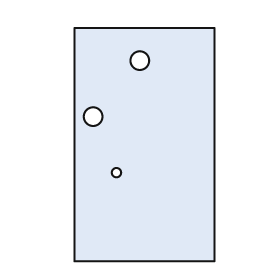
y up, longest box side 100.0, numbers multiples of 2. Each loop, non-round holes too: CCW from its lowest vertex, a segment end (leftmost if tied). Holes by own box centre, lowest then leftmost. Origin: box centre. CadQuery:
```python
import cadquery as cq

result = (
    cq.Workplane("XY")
    .moveTo(-30.0, -50.0)
    .lineTo(30.0, -50.0)
    .lineTo(30.0, 50.0)
    .lineTo(-30.0, 50.0)
    .close()
    .moveTo(-12.0, -12.0)
    .circle(2.0)
    .moveTo(-22.0, 12.0)
    .circle(4.0)
    .moveTo(-2.0, 36.0)
    .circle(4.0)
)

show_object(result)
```